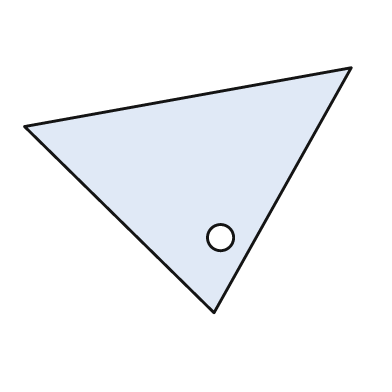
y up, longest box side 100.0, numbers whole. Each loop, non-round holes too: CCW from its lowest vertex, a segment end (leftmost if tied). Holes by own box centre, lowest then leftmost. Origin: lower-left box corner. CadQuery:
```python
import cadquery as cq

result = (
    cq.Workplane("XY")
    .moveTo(58.0, 0.0)
    .lineTo(100.0, 75.0)
    .lineTo(0.0, 57.0)
    .close()
    .moveTo(60.0, 23.0)
    .circle(4.0)
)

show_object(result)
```